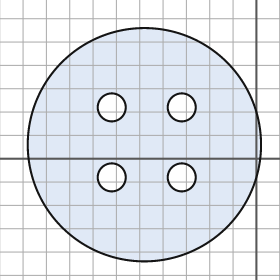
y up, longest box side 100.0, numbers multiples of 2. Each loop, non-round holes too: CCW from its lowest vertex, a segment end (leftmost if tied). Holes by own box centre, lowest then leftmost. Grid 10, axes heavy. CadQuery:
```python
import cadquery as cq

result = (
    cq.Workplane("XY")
    .moveTo(-48.0, 6.0)
    .circle(50.0)
    .moveTo(-62.0, -8.0)
    .circle(6.0)
    .moveTo(-32.0, -8.0)
    .circle(6.0)
    .moveTo(-62.0, 22.0)
    .circle(6.0)
    .moveTo(-32.0, 22.0)
    .circle(6.0)
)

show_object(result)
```